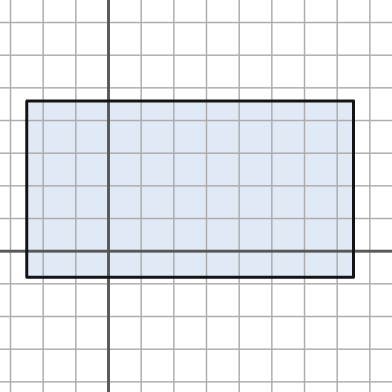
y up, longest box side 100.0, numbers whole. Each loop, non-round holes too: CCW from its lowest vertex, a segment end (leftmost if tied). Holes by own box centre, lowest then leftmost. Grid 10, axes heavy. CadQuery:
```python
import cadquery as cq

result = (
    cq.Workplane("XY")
    .moveTo(-25.0, -8.0)
    .lineTo(75.0, -8.0)
    .lineTo(75.0, 46.0)
    .lineTo(-25.0, 46.0)
    .close()
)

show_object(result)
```